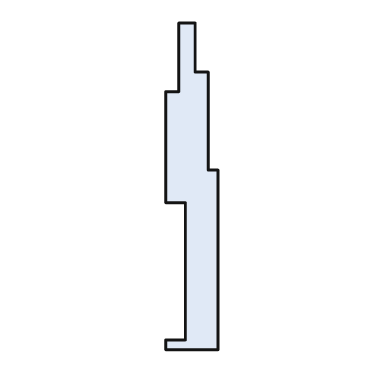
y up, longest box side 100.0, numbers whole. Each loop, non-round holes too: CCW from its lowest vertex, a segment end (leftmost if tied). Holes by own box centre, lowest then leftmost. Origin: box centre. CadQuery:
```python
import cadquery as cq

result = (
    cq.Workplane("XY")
    .moveTo(-8.0, -50.0)
    .lineTo(8.0, -50.0)
    .lineTo(8.0, 5.0)
    .lineTo(5.0, 5.0)
    .lineTo(5.0, 35.0)
    .lineTo(1.0, 35.0)
    .lineTo(1.0, 50.0)
    .lineTo(-4.0, 50.0)
    .lineTo(-4.0, 29.0)
    .lineTo(-8.0, 29.0)
    .lineTo(-8.0, -5.0)
    .lineTo(-2.0, -5.0)
    .lineTo(-2.0, -47.0)
    .lineTo(-8.0, -47.0)
    .close()
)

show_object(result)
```